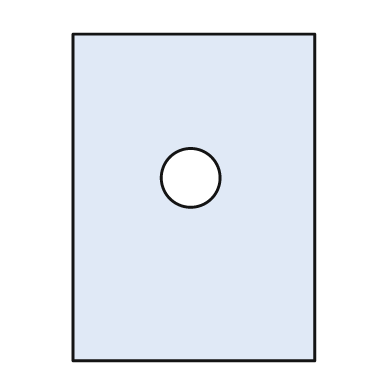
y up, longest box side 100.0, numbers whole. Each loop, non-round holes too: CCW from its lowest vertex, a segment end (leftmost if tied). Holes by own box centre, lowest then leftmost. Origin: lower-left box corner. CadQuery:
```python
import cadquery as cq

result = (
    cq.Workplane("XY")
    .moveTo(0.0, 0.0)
    .lineTo(74.0, 0.0)
    .lineTo(74.0, 100.0)
    .lineTo(0.0, 100.0)
    .close()
    .moveTo(36.0, 56.0)
    .circle(9.0)
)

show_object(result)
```